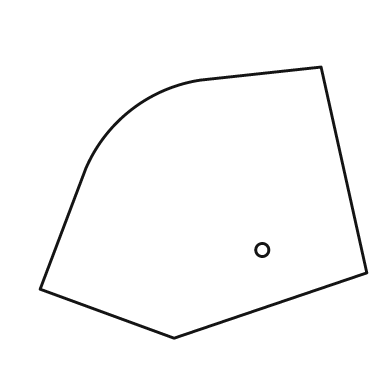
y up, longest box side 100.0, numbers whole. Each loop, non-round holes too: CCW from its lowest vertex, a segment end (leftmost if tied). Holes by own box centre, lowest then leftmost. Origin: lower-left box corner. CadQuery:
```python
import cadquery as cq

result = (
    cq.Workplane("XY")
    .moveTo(41.0, 0.0)
    .lineTo(100.0, 20.0)
    .lineTo(86.0, 83.0)
    .lineTo(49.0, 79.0)
    .threePointArc((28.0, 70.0), (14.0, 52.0))
    .lineTo(0.0, 15.0)
    .close()
    .moveTo(68.0, 27.0)
    .circle(2.0)
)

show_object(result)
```